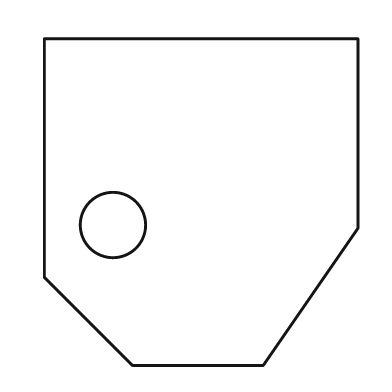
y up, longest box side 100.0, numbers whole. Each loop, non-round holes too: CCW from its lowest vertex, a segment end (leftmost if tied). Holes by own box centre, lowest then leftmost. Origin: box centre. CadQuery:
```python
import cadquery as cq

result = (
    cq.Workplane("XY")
    .moveTo(-21.0, -50.0)
    .lineTo(19.0, -50.0)
    .lineTo(48.0, -8.0)
    .lineTo(48.0, 50.0)
    .lineTo(-48.0, 50.0)
    .lineTo(-48.0, -23.0)
    .close()
    .moveTo(-27.0, -7.0)
    .circle(10.0)
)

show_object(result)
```